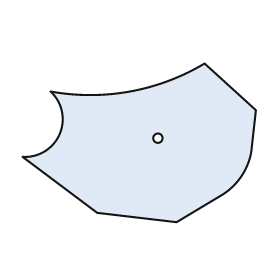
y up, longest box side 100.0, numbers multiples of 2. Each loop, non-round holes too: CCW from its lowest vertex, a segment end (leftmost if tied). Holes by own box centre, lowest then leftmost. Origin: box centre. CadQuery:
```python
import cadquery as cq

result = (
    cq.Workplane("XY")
    .moveTo(16.0, -34.0)
    .lineTo(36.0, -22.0)
    .threePointArc((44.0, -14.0), (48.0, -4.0))
    .lineTo(50.0, 14.0)
    .lineTo(28.0, 34.0)
    .threePointArc((-4.0, 22.0), (-38.0, 22.0))
    .threePointArc((-34.0, 4.0), (-50.0, -6.0))
    .lineTo(-18.0, -30.0)
    .close()
    .moveTo(8.0, 2.0)
    .circle(2.0)
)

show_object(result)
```